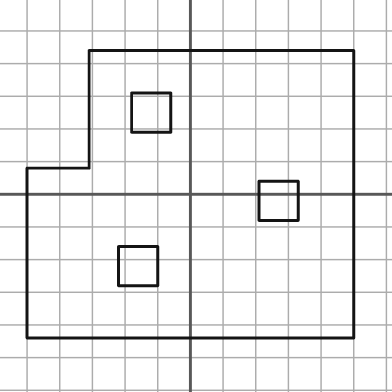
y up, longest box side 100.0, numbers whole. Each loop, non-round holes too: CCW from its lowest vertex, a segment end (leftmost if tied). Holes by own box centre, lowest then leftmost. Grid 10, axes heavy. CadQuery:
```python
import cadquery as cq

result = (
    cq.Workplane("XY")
    .moveTo(-50.0, -44.0)
    .lineTo(50.0, -44.0)
    .lineTo(50.0, 44.0)
    .lineTo(-31.0, 44.0)
    .lineTo(-31.0, 8.0)
    .lineTo(-50.0, 8.0)
    .close()
    .moveTo(-22.0, -28.0)
    .lineTo(-10.0, -28.0)
    .lineTo(-10.0, -16.0)
    .lineTo(-22.0, -16.0)
    .close()
    .moveTo(21.0, -8.0)
    .lineTo(33.0, -8.0)
    .lineTo(33.0, 4.0)
    .lineTo(21.0, 4.0)
    .close()
    .moveTo(-18.0, 19.0)
    .lineTo(-6.0, 19.0)
    .lineTo(-6.0, 31.0)
    .lineTo(-18.0, 31.0)
    .close()
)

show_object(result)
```